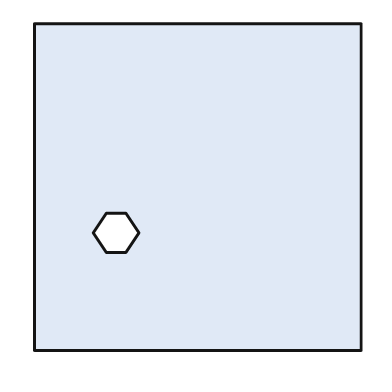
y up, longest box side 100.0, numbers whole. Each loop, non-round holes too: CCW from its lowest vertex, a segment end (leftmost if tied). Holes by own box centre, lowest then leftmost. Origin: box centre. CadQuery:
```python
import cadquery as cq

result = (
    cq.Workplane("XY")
    .moveTo(-50.0, -50.0)
    .lineTo(50.0, -50.0)
    .lineTo(50.0, 50.0)
    .lineTo(-50.0, 50.0)
    .close()
    .moveTo(-28.0, -20.0)
    .lineTo(-22.0, -20.0)
    .lineTo(-18.0, -14.0)
    .lineTo(-22.0, -8.0)
    .lineTo(-28.0, -8.0)
    .lineTo(-32.0, -14.0)
    .close()
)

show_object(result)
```